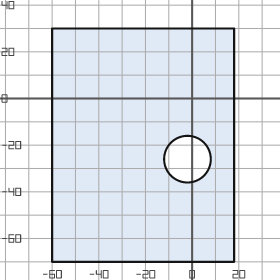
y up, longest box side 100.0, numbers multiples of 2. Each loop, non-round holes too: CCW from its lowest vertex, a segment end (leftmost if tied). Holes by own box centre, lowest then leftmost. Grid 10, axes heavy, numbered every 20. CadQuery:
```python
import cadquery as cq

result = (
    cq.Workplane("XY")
    .moveTo(-60.0, -70.0)
    .lineTo(18.0, -70.0)
    .lineTo(18.0, 30.0)
    .lineTo(-60.0, 30.0)
    .close()
    .moveTo(-2.0, -26.0)
    .circle(10.0)
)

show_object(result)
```